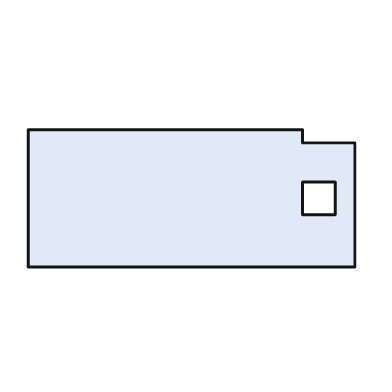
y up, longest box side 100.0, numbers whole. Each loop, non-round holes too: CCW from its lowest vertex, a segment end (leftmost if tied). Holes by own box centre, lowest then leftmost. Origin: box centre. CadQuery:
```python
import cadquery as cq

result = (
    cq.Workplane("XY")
    .moveTo(-50.0, -21.0)
    .lineTo(50.0, -21.0)
    .lineTo(50.0, 17.0)
    .lineTo(34.0, 17.0)
    .lineTo(34.0, 21.0)
    .lineTo(-50.0, 21.0)
    .close()
    .moveTo(34.0, -5.0)
    .lineTo(44.0, -5.0)
    .lineTo(44.0, 5.0)
    .lineTo(34.0, 5.0)
    .close()
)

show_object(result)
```